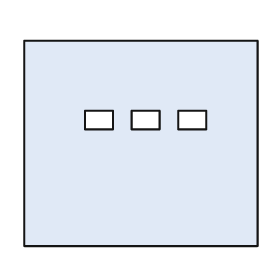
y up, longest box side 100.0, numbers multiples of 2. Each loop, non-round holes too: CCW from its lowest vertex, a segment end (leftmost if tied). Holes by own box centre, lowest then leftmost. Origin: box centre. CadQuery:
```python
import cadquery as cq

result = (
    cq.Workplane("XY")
    .moveTo(-50.0, -44.0)
    .lineTo(50.0, -44.0)
    .lineTo(50.0, 44.0)
    .lineTo(-50.0, 44.0)
    .close()
    .moveTo(-24.0, 6.0)
    .lineTo(-12.0, 6.0)
    .lineTo(-12.0, 14.0)
    .lineTo(-24.0, 14.0)
    .close()
    .moveTo(-4.0, 6.0)
    .lineTo(8.0, 6.0)
    .lineTo(8.0, 14.0)
    .lineTo(-4.0, 14.0)
    .close()
    .moveTo(16.0, 6.0)
    .lineTo(28.0, 6.0)
    .lineTo(28.0, 14.0)
    .lineTo(16.0, 14.0)
    .close()
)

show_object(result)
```